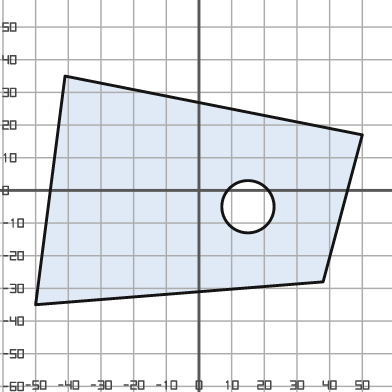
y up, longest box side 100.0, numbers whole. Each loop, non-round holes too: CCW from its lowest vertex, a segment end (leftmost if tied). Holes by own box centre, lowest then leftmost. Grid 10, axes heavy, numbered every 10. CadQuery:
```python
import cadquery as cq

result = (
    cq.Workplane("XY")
    .moveTo(-50.0, -35.0)
    .lineTo(38.0, -28.0)
    .lineTo(50.0, 17.0)
    .lineTo(-41.0, 35.0)
    .close()
    .moveTo(15.0, -5.0)
    .circle(8.0)
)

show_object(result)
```